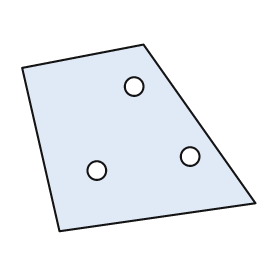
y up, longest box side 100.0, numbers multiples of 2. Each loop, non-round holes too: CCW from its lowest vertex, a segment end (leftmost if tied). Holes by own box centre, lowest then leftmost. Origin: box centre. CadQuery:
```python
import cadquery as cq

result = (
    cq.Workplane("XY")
    .moveTo(-34.0, -40.0)
    .lineTo(50.0, -28.0)
    .lineTo(2.0, 40.0)
    .lineTo(-50.0, 30.0)
    .close()
    .moveTo(-18.0, -14.0)
    .circle(4.0)
    .moveTo(22.0, -8.0)
    .circle(4.0)
    .moveTo(-2.0, 22.0)
    .circle(4.0)
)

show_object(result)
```